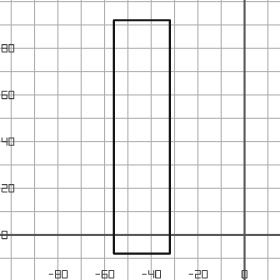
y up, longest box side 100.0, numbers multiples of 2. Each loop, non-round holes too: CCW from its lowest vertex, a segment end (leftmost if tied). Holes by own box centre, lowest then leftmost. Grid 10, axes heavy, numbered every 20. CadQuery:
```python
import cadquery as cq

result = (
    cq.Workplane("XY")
    .moveTo(-56.0, -8.0)
    .lineTo(-32.0, -8.0)
    .lineTo(-32.0, 92.0)
    .lineTo(-56.0, 92.0)
    .close()
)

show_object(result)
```